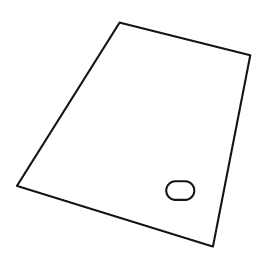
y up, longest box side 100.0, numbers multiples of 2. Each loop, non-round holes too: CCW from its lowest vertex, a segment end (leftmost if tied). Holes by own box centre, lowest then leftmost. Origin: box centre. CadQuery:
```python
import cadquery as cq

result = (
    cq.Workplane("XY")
    .moveTo(34.0, -48.0)
    .lineTo(50.0, 34.0)
    .lineTo(-6.0, 48.0)
    .lineTo(-50.0, -22.0)
    .close()
    .moveTo(18.0, -28.0)
    .lineTo(22.0, -28.0)
    .threePointArc((26.0, -24.0), (22.0, -20.0))
    .lineTo(18.0, -20.0)
    .threePointArc((14.0, -24.0), (18.0, -28.0))
    .close()
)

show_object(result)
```